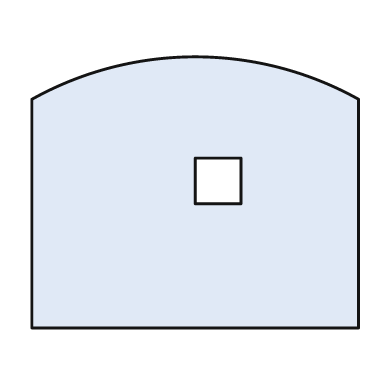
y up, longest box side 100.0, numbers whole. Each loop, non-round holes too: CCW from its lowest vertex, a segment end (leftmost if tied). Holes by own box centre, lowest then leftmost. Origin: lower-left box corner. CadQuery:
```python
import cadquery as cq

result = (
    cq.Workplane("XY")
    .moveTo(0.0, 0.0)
    .lineTo(100.0, 0.0)
    .lineTo(100.0, 70.0)
    .threePointArc((50.0, 83.0), (0.0, 70.0))
    .close()
    .moveTo(50.0, 38.0)
    .lineTo(64.0, 38.0)
    .lineTo(64.0, 52.0)
    .lineTo(50.0, 52.0)
    .close()
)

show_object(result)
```